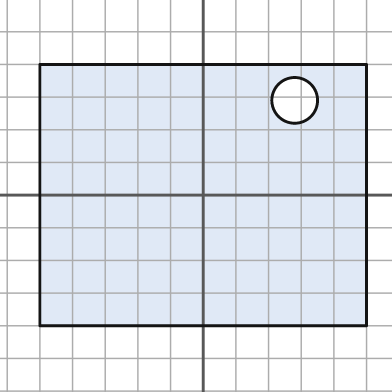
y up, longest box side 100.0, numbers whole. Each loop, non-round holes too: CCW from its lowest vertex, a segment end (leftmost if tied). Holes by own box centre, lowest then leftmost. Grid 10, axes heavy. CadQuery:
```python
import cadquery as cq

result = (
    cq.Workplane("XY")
    .moveTo(-50.0, -40.0)
    .lineTo(50.0, -40.0)
    .lineTo(50.0, 40.0)
    .lineTo(-50.0, 40.0)
    .close()
    .moveTo(28.0, 29.0)
    .circle(7.0)
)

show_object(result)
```